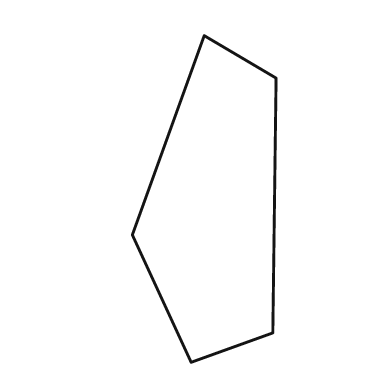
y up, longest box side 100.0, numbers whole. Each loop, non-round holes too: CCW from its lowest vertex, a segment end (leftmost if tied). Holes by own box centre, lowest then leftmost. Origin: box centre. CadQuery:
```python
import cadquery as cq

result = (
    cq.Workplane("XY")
    .moveTo(-4.0, -50.0)
    .lineTo(21.0, -41.0)
    .lineTo(22.0, 37.0)
    .lineTo(0.0, 50.0)
    .lineTo(-22.0, -11.0)
    .close()
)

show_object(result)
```